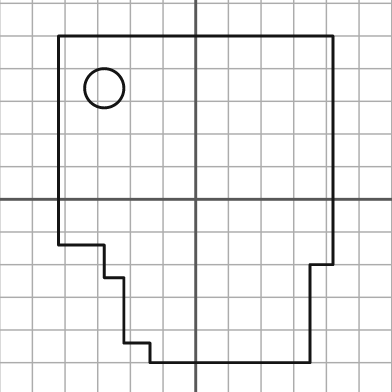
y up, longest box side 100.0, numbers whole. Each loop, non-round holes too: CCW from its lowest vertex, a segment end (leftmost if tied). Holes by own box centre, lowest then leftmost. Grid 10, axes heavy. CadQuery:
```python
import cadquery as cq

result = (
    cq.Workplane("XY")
    .moveTo(-14.0, -50.0)
    .lineTo(35.0, -50.0)
    .lineTo(35.0, -20.0)
    .lineTo(42.0, -20.0)
    .lineTo(42.0, 50.0)
    .lineTo(-42.0, 50.0)
    .lineTo(-42.0, -14.0)
    .lineTo(-28.0, -14.0)
    .lineTo(-28.0, -24.0)
    .lineTo(-22.0, -24.0)
    .lineTo(-22.0, -44.0)
    .lineTo(-14.0, -44.0)
    .close()
    .moveTo(-28.0, 34.0)
    .circle(6.0)
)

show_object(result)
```